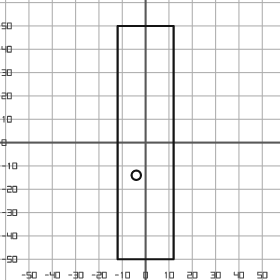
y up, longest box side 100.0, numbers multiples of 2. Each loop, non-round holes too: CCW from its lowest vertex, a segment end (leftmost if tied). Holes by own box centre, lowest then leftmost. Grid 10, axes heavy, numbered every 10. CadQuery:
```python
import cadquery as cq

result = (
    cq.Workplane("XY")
    .moveTo(-12.0, -50.0)
    .lineTo(12.0, -50.0)
    .lineTo(12.0, 50.0)
    .lineTo(-12.0, 50.0)
    .close()
    .moveTo(-4.0, -14.0)
    .circle(2.0)
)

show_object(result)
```